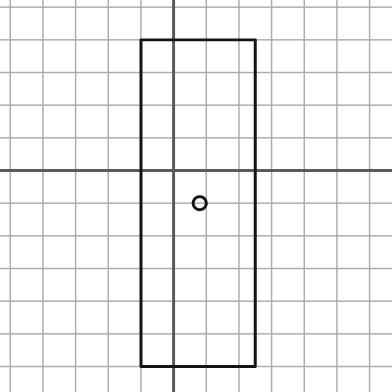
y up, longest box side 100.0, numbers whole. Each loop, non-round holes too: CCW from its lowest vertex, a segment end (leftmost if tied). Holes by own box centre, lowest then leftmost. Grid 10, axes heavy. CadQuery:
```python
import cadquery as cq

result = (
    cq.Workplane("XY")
    .moveTo(-10.0, -60.0)
    .lineTo(25.0, -60.0)
    .lineTo(25.0, 40.0)
    .lineTo(-10.0, 40.0)
    .close()
    .moveTo(8.0, -10.0)
    .circle(2.0)
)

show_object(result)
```